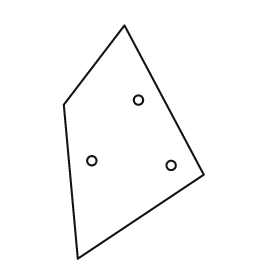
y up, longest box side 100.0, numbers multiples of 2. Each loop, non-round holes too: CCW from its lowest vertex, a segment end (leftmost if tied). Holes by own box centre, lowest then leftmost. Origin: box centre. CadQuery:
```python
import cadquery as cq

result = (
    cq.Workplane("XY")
    .moveTo(-24.0, -50.0)
    .lineTo(30.0, -14.0)
    .lineTo(-4.0, 50.0)
    .lineTo(-30.0, 16.0)
    .close()
    .moveTo(16.0, -10.0)
    .circle(2.0)
    .moveTo(-18.0, -8.0)
    .circle(2.0)
    .moveTo(2.0, 18.0)
    .circle(2.0)
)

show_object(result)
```